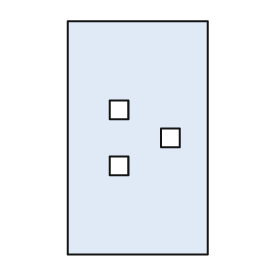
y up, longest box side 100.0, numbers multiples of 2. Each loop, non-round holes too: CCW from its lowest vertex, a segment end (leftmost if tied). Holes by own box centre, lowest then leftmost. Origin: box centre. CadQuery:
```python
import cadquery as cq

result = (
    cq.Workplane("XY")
    .moveTo(-30.0, -50.0)
    .lineTo(30.0, -50.0)
    .lineTo(30.0, 50.0)
    .lineTo(-30.0, 50.0)
    .close()
    .moveTo(-12.0, -16.0)
    .lineTo(-4.0, -16.0)
    .lineTo(-4.0, -8.0)
    .lineTo(-12.0, -8.0)
    .close()
    .moveTo(10.0, -4.0)
    .lineTo(18.0, -4.0)
    .lineTo(18.0, 4.0)
    .lineTo(10.0, 4.0)
    .close()
    .moveTo(-12.0, 8.0)
    .lineTo(-4.0, 8.0)
    .lineTo(-4.0, 16.0)
    .lineTo(-12.0, 16.0)
    .close()
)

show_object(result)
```